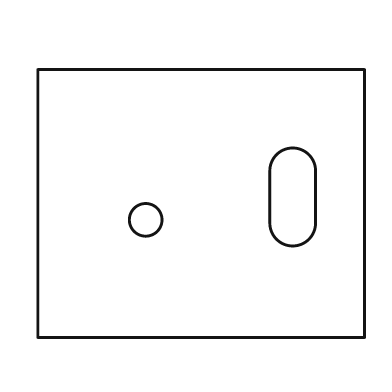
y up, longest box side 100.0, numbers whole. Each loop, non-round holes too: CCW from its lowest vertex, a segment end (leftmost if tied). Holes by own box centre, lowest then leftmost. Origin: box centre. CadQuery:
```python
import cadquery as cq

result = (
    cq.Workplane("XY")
    .moveTo(-50.0, -41.0)
    .lineTo(50.0, -41.0)
    .lineTo(50.0, 41.0)
    .lineTo(-50.0, 41.0)
    .close()
    .moveTo(-17.0, -5.0)
    .circle(5.0)
    .moveTo(21.0, -6.0)
    .threePointArc((28.0, -13.0), (35.0, -6.0))
    .lineTo(35.0, 10.0)
    .threePointArc((28.0, 17.0), (21.0, 10.0))
    .close()
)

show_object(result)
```